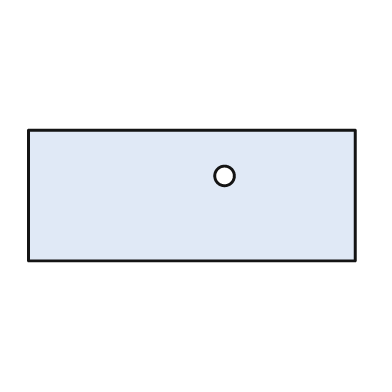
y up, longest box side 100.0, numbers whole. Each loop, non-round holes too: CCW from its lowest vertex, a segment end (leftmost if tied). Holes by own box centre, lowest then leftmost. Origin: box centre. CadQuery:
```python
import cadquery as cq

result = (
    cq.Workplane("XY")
    .moveTo(-50.0, -20.0)
    .lineTo(50.0, -20.0)
    .lineTo(50.0, 20.0)
    .lineTo(-50.0, 20.0)
    .close()
    .moveTo(10.0, 6.0)
    .circle(3.0)
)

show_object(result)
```